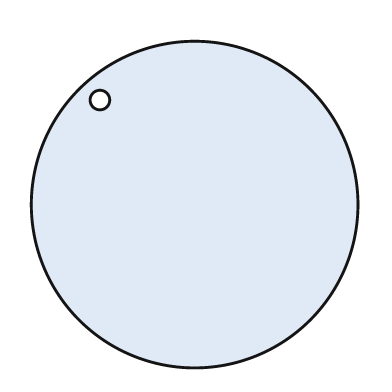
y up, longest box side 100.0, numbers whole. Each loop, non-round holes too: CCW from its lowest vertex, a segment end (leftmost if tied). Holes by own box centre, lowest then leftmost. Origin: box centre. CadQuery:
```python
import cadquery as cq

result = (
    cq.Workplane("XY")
    .moveTo(0.0, 0.0)
    .circle(50.0)
    .moveTo(-29.0, 32.0)
    .circle(3.0)
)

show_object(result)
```